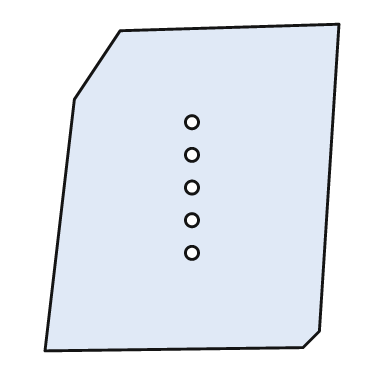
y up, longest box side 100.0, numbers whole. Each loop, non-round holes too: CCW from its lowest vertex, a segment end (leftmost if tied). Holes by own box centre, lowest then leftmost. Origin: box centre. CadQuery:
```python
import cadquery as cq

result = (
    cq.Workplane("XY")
    .moveTo(-45.0, -50.0)
    .lineTo(34.0, -49.0)
    .lineTo(39.0, -44.0)
    .lineTo(45.0, 50.0)
    .lineTo(-22.0, 48.0)
    .lineTo(-36.0, 27.0)
    .close()
    .moveTo(0.0, -20.0)
    .circle(2.0)
    .moveTo(0.0, -10.0)
    .circle(2.0)
    .moveTo(0.0, 0.0)
    .circle(2.0)
    .moveTo(0.0, 10.0)
    .circle(2.0)
    .moveTo(0.0, 20.0)
    .circle(2.0)
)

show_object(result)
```